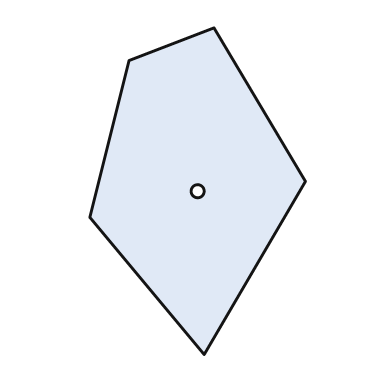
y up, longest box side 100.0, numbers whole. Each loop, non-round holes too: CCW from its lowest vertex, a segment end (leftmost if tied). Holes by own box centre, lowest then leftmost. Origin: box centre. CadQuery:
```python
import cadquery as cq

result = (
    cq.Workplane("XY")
    .moveTo(2.0, -50.0)
    .lineTo(33.0, 3.0)
    .lineTo(5.0, 50.0)
    .lineTo(-21.0, 40.0)
    .lineTo(-33.0, -8.0)
    .close()
    .moveTo(0.0, 0.0)
    .circle(2.0)
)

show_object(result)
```